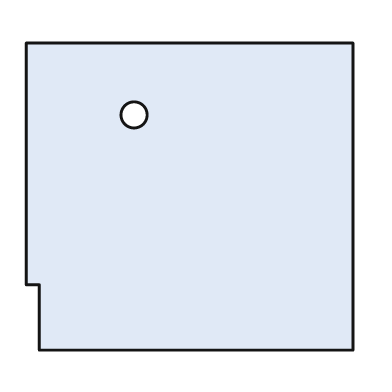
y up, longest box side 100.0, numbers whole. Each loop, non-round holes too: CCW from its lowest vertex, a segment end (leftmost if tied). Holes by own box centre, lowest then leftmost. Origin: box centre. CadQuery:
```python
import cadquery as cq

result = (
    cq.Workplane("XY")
    .moveTo(-46.0, -47.0)
    .lineTo(50.0, -47.0)
    .lineTo(50.0, 47.0)
    .lineTo(-50.0, 47.0)
    .lineTo(-50.0, -27.0)
    .lineTo(-46.0, -27.0)
    .close()
    .moveTo(-17.0, 25.0)
    .circle(4.0)
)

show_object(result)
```